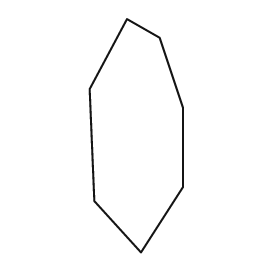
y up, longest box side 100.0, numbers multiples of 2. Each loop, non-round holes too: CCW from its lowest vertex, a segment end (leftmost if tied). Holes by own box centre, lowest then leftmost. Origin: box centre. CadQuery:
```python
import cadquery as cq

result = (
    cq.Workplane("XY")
    .moveTo(2.0, -50.0)
    .lineTo(20.0, -22.0)
    .lineTo(20.0, 12.0)
    .lineTo(10.0, 42.0)
    .lineTo(-4.0, 50.0)
    .lineTo(-20.0, 20.0)
    .lineTo(-18.0, -28.0)
    .close()
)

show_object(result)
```